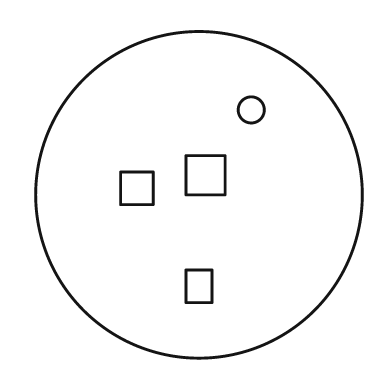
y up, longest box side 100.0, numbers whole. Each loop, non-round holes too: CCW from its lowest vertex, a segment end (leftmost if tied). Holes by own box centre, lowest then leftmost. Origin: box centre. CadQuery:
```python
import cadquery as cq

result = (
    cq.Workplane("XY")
    .moveTo(0.0, 0.0)
    .circle(50.0)
    .moveTo(-4.0, -33.0)
    .lineTo(4.0, -33.0)
    .lineTo(4.0, -23.0)
    .lineTo(-4.0, -23.0)
    .close()
    .moveTo(-24.0, -3.0)
    .lineTo(-14.0, -3.0)
    .lineTo(-14.0, 7.0)
    .lineTo(-24.0, 7.0)
    .close()
    .moveTo(-4.0, 0.0)
    .lineTo(8.0, 0.0)
    .lineTo(8.0, 12.0)
    .lineTo(-4.0, 12.0)
    .close()
    .moveTo(16.0, 26.0)
    .circle(4.0)
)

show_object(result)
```